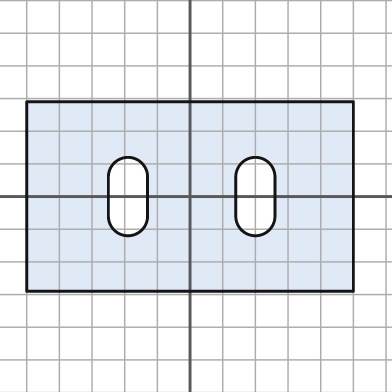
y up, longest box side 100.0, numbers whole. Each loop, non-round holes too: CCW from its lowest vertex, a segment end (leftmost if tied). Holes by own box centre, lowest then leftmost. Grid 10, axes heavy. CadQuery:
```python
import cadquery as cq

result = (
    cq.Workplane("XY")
    .moveTo(-50.0, -29.0)
    .lineTo(50.0, -29.0)
    .lineTo(50.0, 29.0)
    .lineTo(-50.0, 29.0)
    .close()
    .moveTo(-25.0, -6.0)
    .threePointArc((-19.0, -12.0), (-13.0, -6.0))
    .lineTo(-13.0, 6.0)
    .threePointArc((-19.0, 12.0), (-25.0, 6.0))
    .close()
    .moveTo(14.0, -6.0)
    .threePointArc((20.0, -12.0), (26.0, -6.0))
    .lineTo(26.0, 6.0)
    .threePointArc((20.0, 12.0), (14.0, 6.0))
    .close()
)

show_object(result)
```